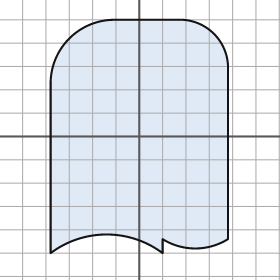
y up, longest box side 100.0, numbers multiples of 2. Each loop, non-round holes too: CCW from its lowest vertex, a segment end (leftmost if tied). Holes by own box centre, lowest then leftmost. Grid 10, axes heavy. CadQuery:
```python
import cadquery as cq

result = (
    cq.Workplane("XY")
    .moveTo(-38.0, -50.0)
    .threePointArc((-14.0, -42.0), (10.0, -50.0))
    .lineTo(10.0, -44.0)
    .threePointArc((24.0, -48.0), (38.0, -44.0))
    .lineTo(38.0, 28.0)
    .threePointArc((32.0, 44.0), (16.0, 50.0))
    .lineTo(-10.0, 50.0)
    .threePointArc((-30.0, 42.0), (-38.0, 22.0))
    .close()
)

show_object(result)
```